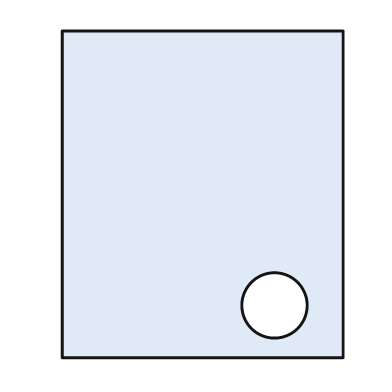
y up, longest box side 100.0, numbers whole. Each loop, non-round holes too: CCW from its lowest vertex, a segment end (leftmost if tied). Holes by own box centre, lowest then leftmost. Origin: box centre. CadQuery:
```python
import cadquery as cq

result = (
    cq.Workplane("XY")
    .moveTo(-43.0, -50.0)
    .lineTo(43.0, -50.0)
    .lineTo(43.0, 50.0)
    .lineTo(-43.0, 50.0)
    .close()
    .moveTo(22.0, -34.0)
    .circle(10.0)
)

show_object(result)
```